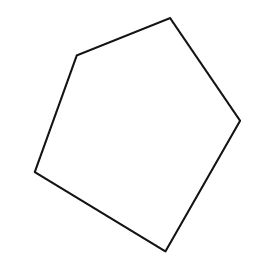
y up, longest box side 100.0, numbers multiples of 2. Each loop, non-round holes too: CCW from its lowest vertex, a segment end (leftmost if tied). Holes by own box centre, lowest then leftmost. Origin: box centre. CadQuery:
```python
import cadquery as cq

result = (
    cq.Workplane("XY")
    .moveTo(12.0, -50.0)
    .lineTo(44.0, 6.0)
    .lineTo(14.0, 50.0)
    .lineTo(-26.0, 34.0)
    .lineTo(-44.0, -16.0)
    .close()
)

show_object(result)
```